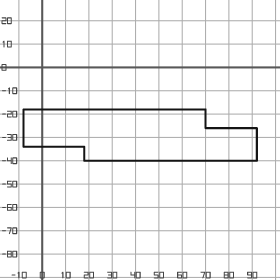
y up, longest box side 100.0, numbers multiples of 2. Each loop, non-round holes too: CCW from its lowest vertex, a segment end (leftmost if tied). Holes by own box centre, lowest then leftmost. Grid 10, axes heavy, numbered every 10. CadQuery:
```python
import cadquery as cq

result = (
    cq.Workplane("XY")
    .moveTo(18.0, -40.0)
    .lineTo(92.0, -40.0)
    .lineTo(92.0, -26.0)
    .lineTo(70.0, -26.0)
    .lineTo(70.0, -18.0)
    .lineTo(-8.0, -18.0)
    .lineTo(-8.0, -34.0)
    .lineTo(18.0, -34.0)
    .close()
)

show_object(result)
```